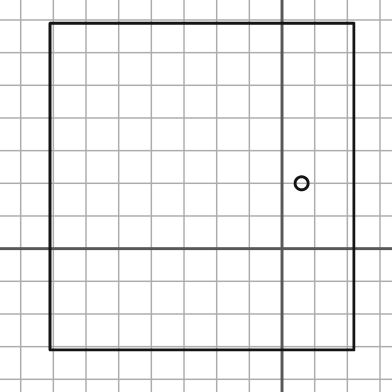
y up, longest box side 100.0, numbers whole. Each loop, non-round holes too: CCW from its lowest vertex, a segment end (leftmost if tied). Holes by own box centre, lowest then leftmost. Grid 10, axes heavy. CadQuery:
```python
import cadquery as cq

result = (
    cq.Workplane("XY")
    .moveTo(-71.0, -31.0)
    .lineTo(22.0, -31.0)
    .lineTo(22.0, 69.0)
    .lineTo(-71.0, 69.0)
    .close()
    .moveTo(6.0, 20.0)
    .circle(2.0)
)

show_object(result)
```